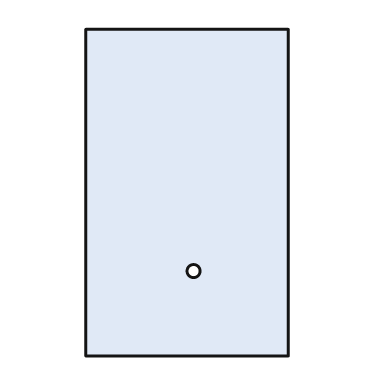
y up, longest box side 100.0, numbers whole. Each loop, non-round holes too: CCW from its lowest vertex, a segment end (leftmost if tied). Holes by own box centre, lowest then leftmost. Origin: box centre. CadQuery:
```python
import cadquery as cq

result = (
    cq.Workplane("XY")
    .moveTo(-31.0, -50.0)
    .lineTo(31.0, -50.0)
    .lineTo(31.0, 50.0)
    .lineTo(-31.0, 50.0)
    .close()
    .moveTo(2.0, -24.0)
    .circle(2.0)
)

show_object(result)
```